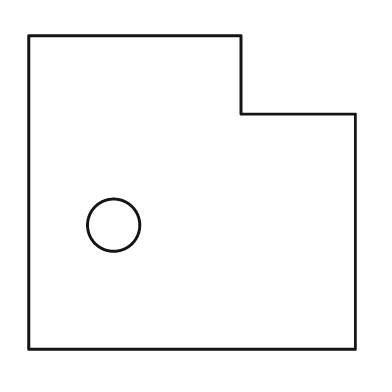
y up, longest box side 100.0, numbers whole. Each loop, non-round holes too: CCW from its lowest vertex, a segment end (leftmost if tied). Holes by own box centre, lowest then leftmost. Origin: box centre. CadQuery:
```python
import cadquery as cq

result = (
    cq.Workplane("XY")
    .moveTo(-50.0, -48.0)
    .lineTo(50.0, -48.0)
    .lineTo(50.0, 24.0)
    .lineTo(15.0, 24.0)
    .lineTo(15.0, 48.0)
    .lineTo(-50.0, 48.0)
    .close()
    .moveTo(-24.0, -10.0)
    .circle(8.0)
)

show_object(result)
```